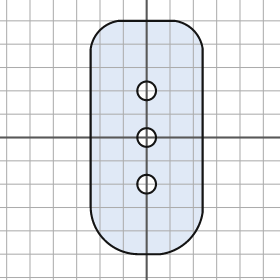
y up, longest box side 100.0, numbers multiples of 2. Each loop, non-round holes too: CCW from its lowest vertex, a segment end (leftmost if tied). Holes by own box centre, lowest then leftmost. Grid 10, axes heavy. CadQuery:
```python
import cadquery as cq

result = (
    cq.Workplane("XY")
    .moveTo(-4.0, -50.0)
    .lineTo(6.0, -50.0)
    .threePointArc((18.0, -44.0), (24.0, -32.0))
    .lineTo(24.0, 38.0)
    .threePointArc((20.0, 46.0), (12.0, 50.0))
    .lineTo(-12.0, 50.0)
    .threePointArc((-20.0, 46.0), (-24.0, 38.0))
    .lineTo(-24.0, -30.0)
    .threePointArc((-18.0, -44.0), (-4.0, -50.0))
    .close()
    .moveTo(0.0, -20.0)
    .circle(4.0)
    .moveTo(0.0, 0.0)
    .circle(4.0)
    .moveTo(0.0, 20.0)
    .circle(4.0)
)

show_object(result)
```